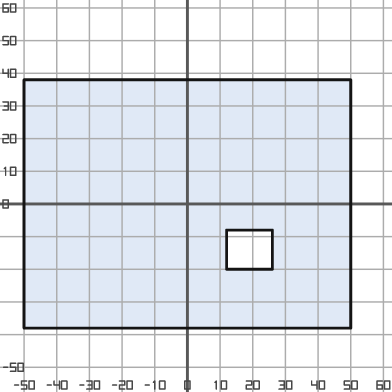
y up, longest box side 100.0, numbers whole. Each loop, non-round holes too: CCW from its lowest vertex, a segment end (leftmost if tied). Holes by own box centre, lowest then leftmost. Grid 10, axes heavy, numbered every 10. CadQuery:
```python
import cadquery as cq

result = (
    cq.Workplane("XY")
    .moveTo(-50.0, -38.0)
    .lineTo(50.0, -38.0)
    .lineTo(50.0, 38.0)
    .lineTo(-50.0, 38.0)
    .close()
    .moveTo(12.0, -20.0)
    .lineTo(26.0, -20.0)
    .lineTo(26.0, -8.0)
    .lineTo(12.0, -8.0)
    .close()
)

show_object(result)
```